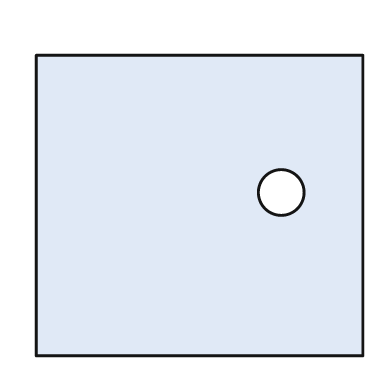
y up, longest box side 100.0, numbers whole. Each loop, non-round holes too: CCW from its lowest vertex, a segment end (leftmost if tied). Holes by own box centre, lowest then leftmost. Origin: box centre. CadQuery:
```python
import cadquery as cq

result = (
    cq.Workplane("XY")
    .moveTo(-50.0, -46.0)
    .lineTo(50.0, -46.0)
    .lineTo(50.0, 46.0)
    .lineTo(-50.0, 46.0)
    .close()
    .moveTo(25.0, 4.0)
    .circle(7.0)
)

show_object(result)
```